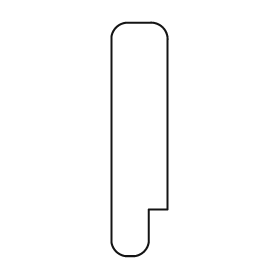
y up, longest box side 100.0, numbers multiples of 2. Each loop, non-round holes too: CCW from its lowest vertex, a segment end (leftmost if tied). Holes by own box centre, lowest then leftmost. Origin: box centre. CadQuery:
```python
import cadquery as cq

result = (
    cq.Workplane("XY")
    .moveTo(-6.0, -50.0)
    .lineTo(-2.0, -50.0)
    .threePointArc((2.0, -48.0), (4.0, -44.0))
    .lineTo(4.0, -30.0)
    .lineTo(12.0, -30.0)
    .lineTo(12.0, 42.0)
    .threePointArc((10.0, 48.0), (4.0, 50.0))
    .lineTo(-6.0, 50.0)
    .threePointArc((-10.0, 48.0), (-12.0, 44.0))
    .lineTo(-12.0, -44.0)
    .threePointArc((-10.0, -48.0), (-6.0, -50.0))
    .close()
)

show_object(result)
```